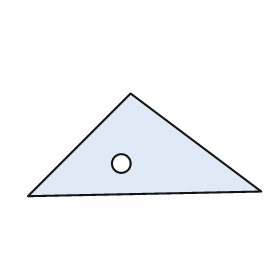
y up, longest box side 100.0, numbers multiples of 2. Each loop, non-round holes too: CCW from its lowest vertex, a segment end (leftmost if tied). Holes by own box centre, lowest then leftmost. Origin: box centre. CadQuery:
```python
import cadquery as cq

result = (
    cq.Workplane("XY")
    .moveTo(-50.0, -22.0)
    .lineTo(50.0, -20.0)
    .lineTo(-6.0, 22.0)
    .close()
    .moveTo(-10.0, -8.0)
    .circle(4.0)
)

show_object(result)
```